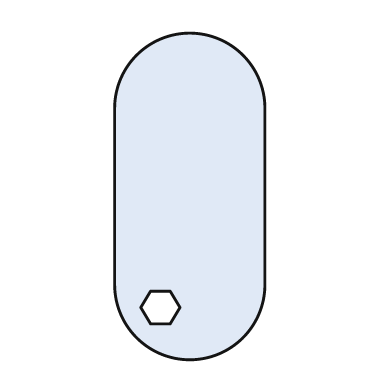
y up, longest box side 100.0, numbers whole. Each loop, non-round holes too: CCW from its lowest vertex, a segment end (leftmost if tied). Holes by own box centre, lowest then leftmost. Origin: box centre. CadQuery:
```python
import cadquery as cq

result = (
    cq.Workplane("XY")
    .moveTo(-23.0, -27.0)
    .threePointArc((0.0, -50.0), (23.0, -27.0))
    .lineTo(23.0, 27.0)
    .threePointArc((0.0, 50.0), (-23.0, 27.0))
    .close()
    .moveTo(-12.0, -39.0)
    .lineTo(-6.0, -39.0)
    .lineTo(-3.0, -34.0)
    .lineTo(-6.0, -29.0)
    .lineTo(-12.0, -29.0)
    .lineTo(-15.0, -34.0)
    .close()
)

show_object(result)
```